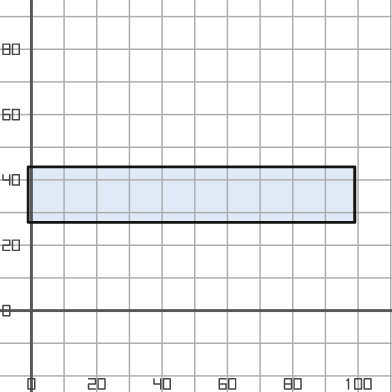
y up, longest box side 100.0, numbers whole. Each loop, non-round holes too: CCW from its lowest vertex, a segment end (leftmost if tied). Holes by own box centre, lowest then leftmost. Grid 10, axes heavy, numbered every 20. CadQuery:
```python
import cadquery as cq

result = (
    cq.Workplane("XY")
    .moveTo(-1.0, 27.0)
    .lineTo(99.0, 27.0)
    .lineTo(99.0, 44.0)
    .lineTo(-1.0, 44.0)
    .close()
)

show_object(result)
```